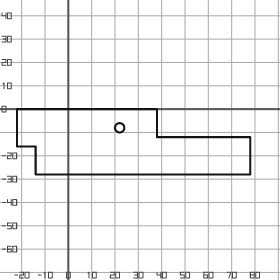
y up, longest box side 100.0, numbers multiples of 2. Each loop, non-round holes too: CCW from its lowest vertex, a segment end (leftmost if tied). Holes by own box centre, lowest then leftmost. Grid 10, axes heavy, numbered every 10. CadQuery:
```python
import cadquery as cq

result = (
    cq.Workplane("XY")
    .moveTo(-14.0, -28.0)
    .lineTo(78.0, -28.0)
    .lineTo(78.0, -12.0)
    .lineTo(38.0, -12.0)
    .lineTo(38.0, 0.0)
    .lineTo(-22.0, 0.0)
    .lineTo(-22.0, -16.0)
    .lineTo(-14.0, -16.0)
    .close()
    .moveTo(22.0, -8.0)
    .circle(2.0)
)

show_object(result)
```